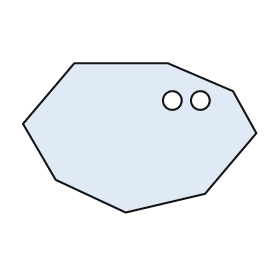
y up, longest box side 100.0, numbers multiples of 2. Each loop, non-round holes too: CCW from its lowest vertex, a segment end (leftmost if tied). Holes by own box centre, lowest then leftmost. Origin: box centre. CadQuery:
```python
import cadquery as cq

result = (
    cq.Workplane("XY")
    .moveTo(-6.0, -32.0)
    .lineTo(28.0, -24.0)
    .lineTo(50.0, 2.0)
    .lineTo(40.0, 20.0)
    .lineTo(12.0, 32.0)
    .lineTo(-28.0, 32.0)
    .lineTo(-50.0, 6.0)
    .lineTo(-36.0, -18.0)
    .close()
    .moveTo(14.0, 16.0)
    .circle(4.0)
    .moveTo(26.0, 16.0)
    .circle(4.0)
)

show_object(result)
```